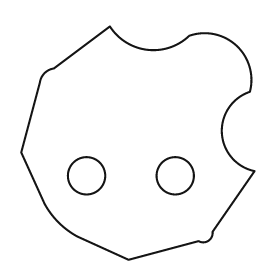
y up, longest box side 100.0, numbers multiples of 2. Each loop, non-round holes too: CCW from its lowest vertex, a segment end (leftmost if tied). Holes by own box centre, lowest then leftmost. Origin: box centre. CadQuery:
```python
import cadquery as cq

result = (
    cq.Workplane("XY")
    .moveTo(-4.0, -50.0)
    .lineTo(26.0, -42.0)
    .threePointArc((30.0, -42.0), (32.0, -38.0))
    .lineTo(50.0, -12.0)
    .threePointArc((36.0, 4.0), (48.0, 22.0))
    .threePointArc((42.0, 42.0), (22.0, 46.0))
    .threePointArc((4.0, 40.0), (-12.0, 50.0))
    .lineTo(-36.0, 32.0)
    .threePointArc((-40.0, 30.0), (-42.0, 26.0))
    .lineTo(-50.0, -4.0)
    .lineTo(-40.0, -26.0)
    .threePointArc((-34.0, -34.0), (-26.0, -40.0))
    .close()
    .moveTo(-22.0, -14.0)
    .circle(8.0)
    .moveTo(16.0, -14.0)
    .circle(8.0)
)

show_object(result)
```